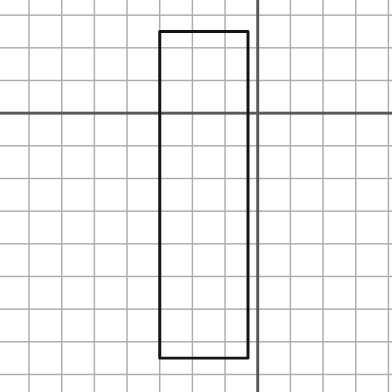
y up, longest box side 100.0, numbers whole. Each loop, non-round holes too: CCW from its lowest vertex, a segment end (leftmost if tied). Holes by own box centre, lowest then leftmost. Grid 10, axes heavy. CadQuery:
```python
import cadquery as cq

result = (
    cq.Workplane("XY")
    .moveTo(-30.0, -75.0)
    .lineTo(-3.0, -75.0)
    .lineTo(-3.0, 25.0)
    .lineTo(-30.0, 25.0)
    .close()
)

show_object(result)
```